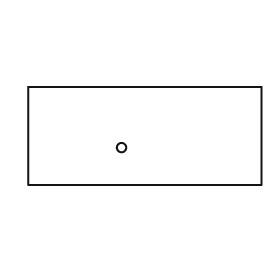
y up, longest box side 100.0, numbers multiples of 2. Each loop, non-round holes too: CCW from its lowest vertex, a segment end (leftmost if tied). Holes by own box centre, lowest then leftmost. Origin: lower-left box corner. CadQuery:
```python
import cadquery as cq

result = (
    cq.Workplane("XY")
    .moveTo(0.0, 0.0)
    .lineTo(100.0, 0.0)
    .lineTo(100.0, 42.0)
    .lineTo(0.0, 42.0)
    .close()
    .moveTo(40.0, 16.0)
    .circle(2.0)
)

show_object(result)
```